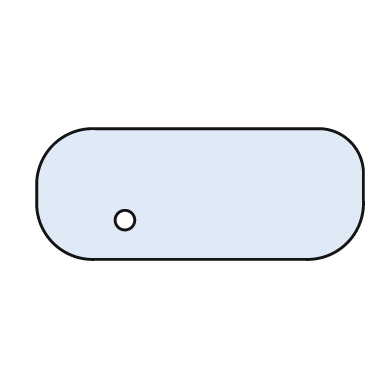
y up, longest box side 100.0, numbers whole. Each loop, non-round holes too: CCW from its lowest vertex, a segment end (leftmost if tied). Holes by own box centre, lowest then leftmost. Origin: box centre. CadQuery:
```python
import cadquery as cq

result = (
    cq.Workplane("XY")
    .moveTo(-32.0, -20.0)
    .lineTo(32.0, -20.0)
    .threePointArc((45.0, -15.0), (50.0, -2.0))
    .lineTo(50.0, 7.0)
    .threePointArc((46.0, 16.0), (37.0, 20.0))
    .lineTo(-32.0, 20.0)
    .threePointArc((-45.0, 15.0), (-50.0, 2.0))
    .lineTo(-50.0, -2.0)
    .threePointArc((-45.0, -15.0), (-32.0, -20.0))
    .close()
    .moveTo(-23.0, -8.0)
    .circle(3.0)
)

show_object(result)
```